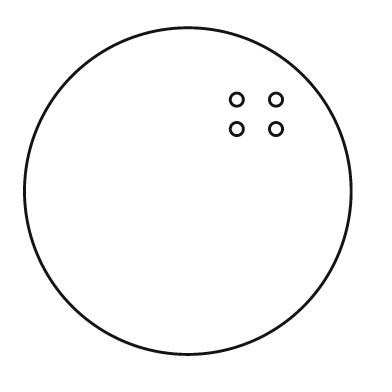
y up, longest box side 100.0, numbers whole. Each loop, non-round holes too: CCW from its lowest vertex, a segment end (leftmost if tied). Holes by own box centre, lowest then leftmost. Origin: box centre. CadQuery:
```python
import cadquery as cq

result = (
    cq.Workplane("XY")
    .moveTo(0.0, 0.0)
    .circle(50.0)
    .moveTo(15.0, 19.0)
    .circle(2.0)
    .moveTo(27.0, 19.0)
    .circle(2.0)
    .moveTo(15.0, 28.0)
    .circle(2.0)
    .moveTo(27.0, 28.0)
    .circle(2.0)
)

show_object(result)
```